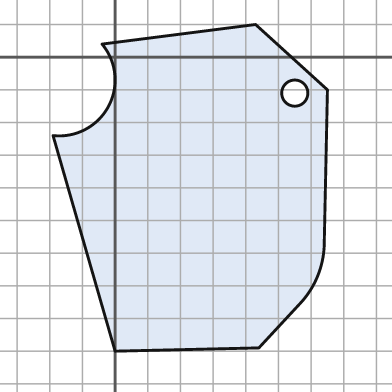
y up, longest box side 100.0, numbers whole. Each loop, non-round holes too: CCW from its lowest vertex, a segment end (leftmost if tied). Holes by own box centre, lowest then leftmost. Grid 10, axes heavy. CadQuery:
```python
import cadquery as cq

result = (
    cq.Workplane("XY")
    .moveTo(0.0, -90.0)
    .lineTo(44.0, -89.0)
    .lineTo(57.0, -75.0)
    .threePointArc((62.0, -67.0), (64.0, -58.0))
    .lineTo(65.0, -10.0)
    .lineTo(43.0, 10.0)
    .lineTo(-4.0, 4.0)
    .threePointArc((-2.0, -15.0), (-19.0, -24.0))
    .close()
    .moveTo(55.0, -11.0)
    .circle(4.0)
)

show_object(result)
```